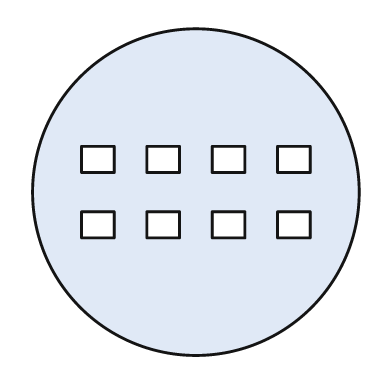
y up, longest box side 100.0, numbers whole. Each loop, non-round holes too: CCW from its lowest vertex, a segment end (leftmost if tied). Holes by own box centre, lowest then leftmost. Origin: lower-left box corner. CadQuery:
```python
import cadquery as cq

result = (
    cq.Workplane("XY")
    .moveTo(50.0, 50.0)
    .circle(50.0)
    .moveTo(15.0, 36.0)
    .lineTo(25.0, 36.0)
    .lineTo(25.0, 44.0)
    .lineTo(15.0, 44.0)
    .close()
    .moveTo(35.0, 36.0)
    .lineTo(45.0, 36.0)
    .lineTo(45.0, 44.0)
    .lineTo(35.0, 44.0)
    .close()
    .moveTo(55.0, 36.0)
    .lineTo(65.0, 36.0)
    .lineTo(65.0, 44.0)
    .lineTo(55.0, 44.0)
    .close()
    .moveTo(75.0, 36.0)
    .lineTo(85.0, 36.0)
    .lineTo(85.0, 44.0)
    .lineTo(75.0, 44.0)
    .close()
    .moveTo(15.0, 56.0)
    .lineTo(25.0, 56.0)
    .lineTo(25.0, 64.0)
    .lineTo(15.0, 64.0)
    .close()
    .moveTo(35.0, 56.0)
    .lineTo(45.0, 56.0)
    .lineTo(45.0, 64.0)
    .lineTo(35.0, 64.0)
    .close()
    .moveTo(55.0, 56.0)
    .lineTo(65.0, 56.0)
    .lineTo(65.0, 64.0)
    .lineTo(55.0, 64.0)
    .close()
    .moveTo(75.0, 56.0)
    .lineTo(85.0, 56.0)
    .lineTo(85.0, 64.0)
    .lineTo(75.0, 64.0)
    .close()
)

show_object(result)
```